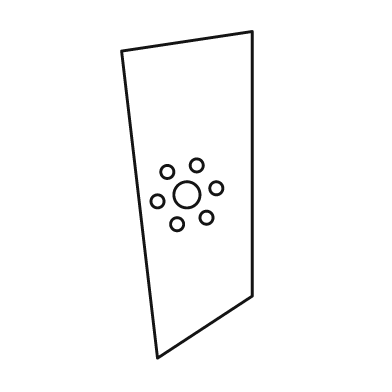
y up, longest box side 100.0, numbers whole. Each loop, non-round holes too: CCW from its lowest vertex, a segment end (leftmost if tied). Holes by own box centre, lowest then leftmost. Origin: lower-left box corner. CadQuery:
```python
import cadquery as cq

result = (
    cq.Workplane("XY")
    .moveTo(11.0, 0.0)
    .lineTo(40.0, 19.0)
    .lineTo(40.0, 100.0)
    .lineTo(0.0, 94.0)
    .close()
    .moveTo(17.0, 41.0)
    .circle(2.0)
    .moveTo(26.0, 43.0)
    .circle(2.0)
    .moveTo(11.0, 48.0)
    .circle(2.0)
    .moveTo(20.0, 50.0)
    .circle(4.0)
    .moveTo(29.0, 52.0)
    .circle(2.0)
    .moveTo(14.0, 57.0)
    .circle(2.0)
    .moveTo(23.0, 59.0)
    .circle(2.0)
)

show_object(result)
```